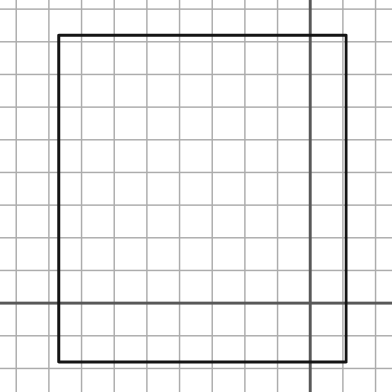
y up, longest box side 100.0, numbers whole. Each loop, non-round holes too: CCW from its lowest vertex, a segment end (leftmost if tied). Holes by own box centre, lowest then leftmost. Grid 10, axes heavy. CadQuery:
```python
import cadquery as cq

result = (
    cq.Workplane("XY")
    .moveTo(-77.0, -18.0)
    .lineTo(11.0, -18.0)
    .lineTo(11.0, 82.0)
    .lineTo(-77.0, 82.0)
    .close()
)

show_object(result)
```